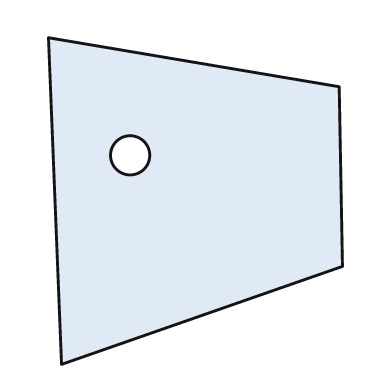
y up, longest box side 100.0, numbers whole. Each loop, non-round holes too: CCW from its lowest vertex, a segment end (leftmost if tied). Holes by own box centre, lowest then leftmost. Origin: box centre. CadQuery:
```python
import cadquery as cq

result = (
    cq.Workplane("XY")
    .moveTo(-41.0, -50.0)
    .lineTo(45.0, -20.0)
    .lineTo(44.0, 35.0)
    .lineTo(-45.0, 50.0)
    .close()
    .moveTo(-20.0, 14.0)
    .circle(6.0)
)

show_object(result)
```